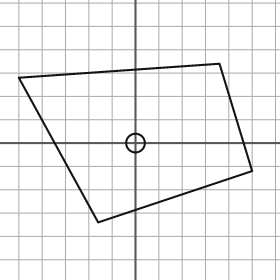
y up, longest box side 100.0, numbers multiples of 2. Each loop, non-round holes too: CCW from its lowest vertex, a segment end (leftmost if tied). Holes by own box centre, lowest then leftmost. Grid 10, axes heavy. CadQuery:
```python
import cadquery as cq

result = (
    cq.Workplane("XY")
    .moveTo(-16.0, -34.0)
    .lineTo(50.0, -12.0)
    .lineTo(36.0, 34.0)
    .lineTo(-50.0, 28.0)
    .close()
    .moveTo(0.0, 0.0)
    .circle(4.0)
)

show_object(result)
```